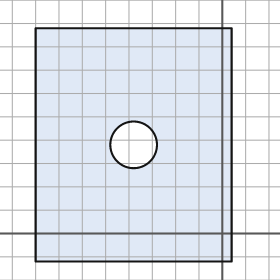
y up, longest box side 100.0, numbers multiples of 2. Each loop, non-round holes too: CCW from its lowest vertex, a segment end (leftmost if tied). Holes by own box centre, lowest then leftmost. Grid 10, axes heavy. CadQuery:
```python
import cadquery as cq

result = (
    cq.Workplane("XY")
    .moveTo(-80.0, -12.0)
    .lineTo(4.0, -12.0)
    .lineTo(4.0, 88.0)
    .lineTo(-80.0, 88.0)
    .close()
    .moveTo(-38.0, 38.0)
    .circle(10.0)
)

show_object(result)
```